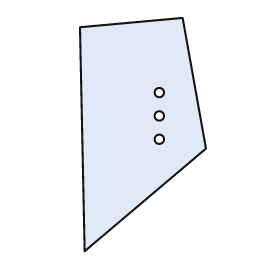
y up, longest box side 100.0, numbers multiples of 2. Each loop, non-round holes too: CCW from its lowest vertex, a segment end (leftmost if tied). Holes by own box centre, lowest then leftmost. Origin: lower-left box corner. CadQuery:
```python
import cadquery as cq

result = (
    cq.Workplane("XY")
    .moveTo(2.0, 0.0)
    .lineTo(54.0, 44.0)
    .lineTo(44.0, 100.0)
    .lineTo(0.0, 96.0)
    .close()
    .moveTo(34.0, 48.0)
    .circle(2.0)
    .moveTo(34.0, 58.0)
    .circle(2.0)
    .moveTo(34.0, 68.0)
    .circle(2.0)
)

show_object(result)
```